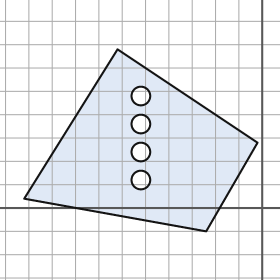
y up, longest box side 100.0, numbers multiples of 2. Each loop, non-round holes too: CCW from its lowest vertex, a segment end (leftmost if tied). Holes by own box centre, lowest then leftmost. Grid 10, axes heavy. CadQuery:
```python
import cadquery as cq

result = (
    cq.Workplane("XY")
    .moveTo(-24.0, -10.0)
    .lineTo(-2.0, 28.0)
    .lineTo(-62.0, 68.0)
    .lineTo(-102.0, 4.0)
    .close()
    .moveTo(-52.0, 12.0)
    .circle(4.0)
    .moveTo(-52.0, 24.0)
    .circle(4.0)
    .moveTo(-52.0, 36.0)
    .circle(4.0)
    .moveTo(-52.0, 48.0)
    .circle(4.0)
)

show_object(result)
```